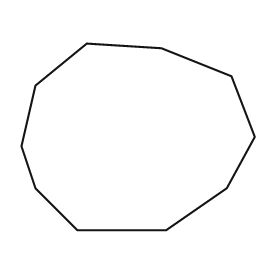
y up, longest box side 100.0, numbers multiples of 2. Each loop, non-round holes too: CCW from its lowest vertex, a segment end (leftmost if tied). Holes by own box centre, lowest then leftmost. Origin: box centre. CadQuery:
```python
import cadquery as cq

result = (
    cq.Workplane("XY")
    .moveTo(-26.0, -40.0)
    .lineTo(12.0, -40.0)
    .lineTo(38.0, -22.0)
    .lineTo(50.0, 0.0)
    .lineTo(40.0, 26.0)
    .lineTo(10.0, 38.0)
    .lineTo(-22.0, 40.0)
    .lineTo(-44.0, 22.0)
    .lineTo(-50.0, -4.0)
    .lineTo(-44.0, -22.0)
    .close()
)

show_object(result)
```